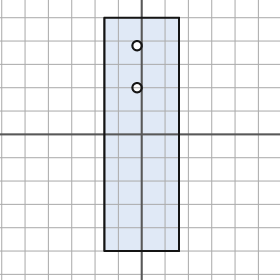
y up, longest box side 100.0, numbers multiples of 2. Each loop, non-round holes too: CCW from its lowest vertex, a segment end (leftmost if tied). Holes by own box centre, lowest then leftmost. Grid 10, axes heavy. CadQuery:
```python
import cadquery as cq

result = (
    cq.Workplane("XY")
    .moveTo(-16.0, -50.0)
    .lineTo(16.0, -50.0)
    .lineTo(16.0, 50.0)
    .lineTo(-16.0, 50.0)
    .close()
    .moveTo(-2.0, 20.0)
    .circle(2.0)
    .moveTo(-2.0, 38.0)
    .circle(2.0)
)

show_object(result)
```